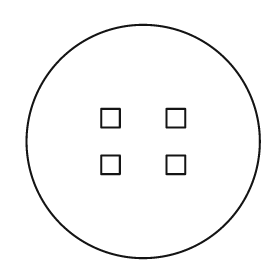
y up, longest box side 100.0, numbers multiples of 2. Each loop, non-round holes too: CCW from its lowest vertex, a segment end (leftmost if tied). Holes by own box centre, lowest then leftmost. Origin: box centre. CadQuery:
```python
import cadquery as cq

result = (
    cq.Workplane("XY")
    .moveTo(0.0, 0.0)
    .circle(50.0)
    .moveTo(-18.0, -14.0)
    .lineTo(-10.0, -14.0)
    .lineTo(-10.0, -6.0)
    .lineTo(-18.0, -6.0)
    .close()
    .moveTo(10.0, -14.0)
    .lineTo(18.0, -14.0)
    .lineTo(18.0, -6.0)
    .lineTo(10.0, -6.0)
    .close()
    .moveTo(-18.0, 6.0)
    .lineTo(-10.0, 6.0)
    .lineTo(-10.0, 14.0)
    .lineTo(-18.0, 14.0)
    .close()
    .moveTo(10.0, 6.0)
    .lineTo(18.0, 6.0)
    .lineTo(18.0, 14.0)
    .lineTo(10.0, 14.0)
    .close()
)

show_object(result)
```